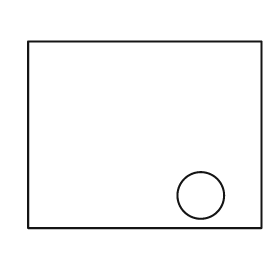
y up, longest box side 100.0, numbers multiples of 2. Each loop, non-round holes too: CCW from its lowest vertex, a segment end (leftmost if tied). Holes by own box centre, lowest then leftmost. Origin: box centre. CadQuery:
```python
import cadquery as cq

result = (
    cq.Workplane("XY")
    .moveTo(-50.0, -40.0)
    .lineTo(50.0, -40.0)
    .lineTo(50.0, 40.0)
    .lineTo(-50.0, 40.0)
    .close()
    .moveTo(24.0, -26.0)
    .circle(10.0)
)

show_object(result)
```